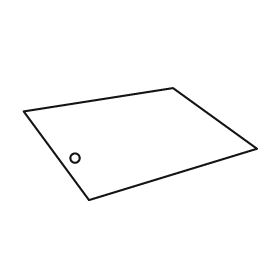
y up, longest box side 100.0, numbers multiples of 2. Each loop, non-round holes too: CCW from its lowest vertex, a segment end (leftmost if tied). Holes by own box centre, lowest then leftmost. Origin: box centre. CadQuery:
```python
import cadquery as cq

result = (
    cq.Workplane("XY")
    .moveTo(-22.0, -24.0)
    .lineTo(50.0, -2.0)
    .lineTo(14.0, 24.0)
    .lineTo(-50.0, 14.0)
    .close()
    .moveTo(-28.0, -6.0)
    .circle(2.0)
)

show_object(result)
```